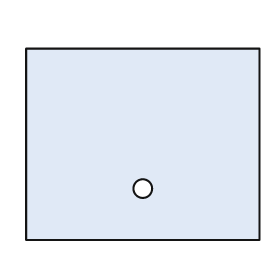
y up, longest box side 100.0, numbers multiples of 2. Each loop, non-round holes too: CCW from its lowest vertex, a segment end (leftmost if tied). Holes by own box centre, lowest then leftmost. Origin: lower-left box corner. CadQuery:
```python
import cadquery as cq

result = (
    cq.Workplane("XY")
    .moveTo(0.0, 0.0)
    .lineTo(100.0, 0.0)
    .lineTo(100.0, 82.0)
    .lineTo(0.0, 82.0)
    .close()
    .moveTo(50.0, 22.0)
    .circle(4.0)
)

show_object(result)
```